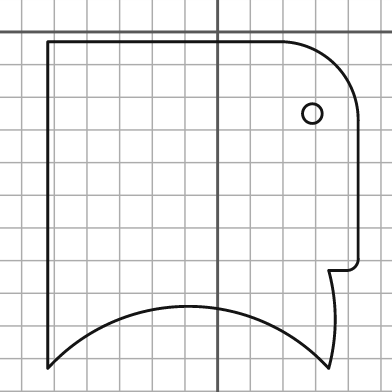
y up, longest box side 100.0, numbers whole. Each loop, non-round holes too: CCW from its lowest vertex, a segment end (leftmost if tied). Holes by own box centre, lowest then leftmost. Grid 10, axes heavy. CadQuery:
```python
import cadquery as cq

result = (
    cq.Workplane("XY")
    .moveTo(-52.0, -103.0)
    .threePointArc((-9.0, -84.0), (34.0, -103.0))
    .threePointArc((36.0, -88.0), (34.0, -73.0))
    .lineTo(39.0, -73.0)
    .threePointArc((42.0, -72.0), (43.0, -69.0))
    .lineTo(43.0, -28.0)
    .threePointArc((36.0, -10.0), (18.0, -3.0))
    .lineTo(-52.0, -3.0)
    .close()
    .moveTo(29.0, -25.0)
    .circle(3.0)
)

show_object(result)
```